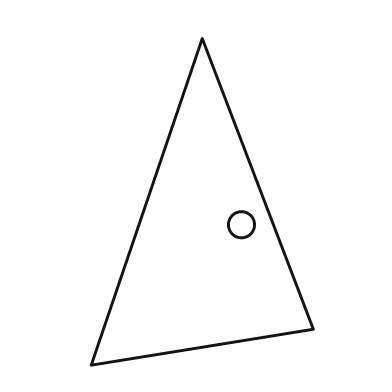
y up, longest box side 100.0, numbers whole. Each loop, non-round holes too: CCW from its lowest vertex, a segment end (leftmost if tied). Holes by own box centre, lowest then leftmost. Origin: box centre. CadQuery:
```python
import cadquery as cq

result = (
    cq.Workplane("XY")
    .moveTo(-34.0, -50.0)
    .lineTo(34.0, -39.0)
    .lineTo(0.0, 50.0)
    .close()
    .moveTo(12.0, -7.0)
    .circle(4.0)
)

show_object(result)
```